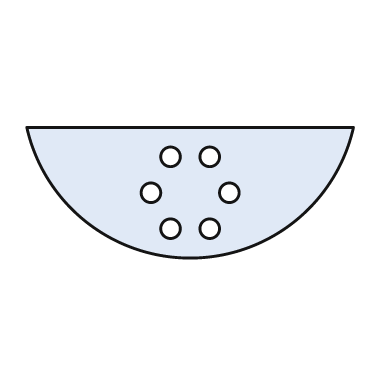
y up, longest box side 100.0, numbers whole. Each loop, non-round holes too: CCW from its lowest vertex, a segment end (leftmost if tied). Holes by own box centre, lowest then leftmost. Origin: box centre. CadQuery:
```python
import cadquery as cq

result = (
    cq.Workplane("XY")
    .moveTo(-50.0, 20.0)
    .threePointArc((0.0, -20.0), (50.0, 20.0))
    .close()
    .moveTo(-6.0, -11.0)
    .circle(3.0)
    .moveTo(6.0, -11.0)
    .circle(3.0)
    .moveTo(-12.0, 0.0)
    .circle(3.0)
    .moveTo(12.0, 0.0)
    .circle(3.0)
    .moveTo(-6.0, 11.0)
    .circle(3.0)
    .moveTo(6.0, 11.0)
    .circle(3.0)
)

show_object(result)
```